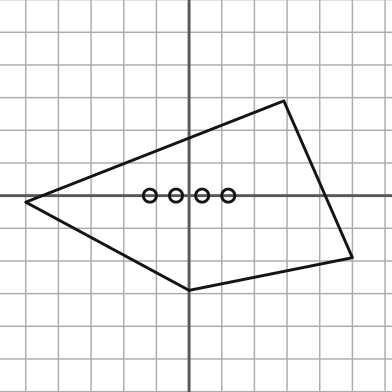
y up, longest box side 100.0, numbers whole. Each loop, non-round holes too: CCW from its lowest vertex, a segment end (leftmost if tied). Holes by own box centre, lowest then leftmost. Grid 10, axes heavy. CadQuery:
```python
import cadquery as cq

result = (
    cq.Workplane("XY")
    .moveTo(0.0, -29.0)
    .lineTo(50.0, -19.0)
    .lineTo(29.0, 29.0)
    .lineTo(-50.0, -2.0)
    .close()
    .moveTo(-12.0, 0.0)
    .circle(2.0)
    .moveTo(-4.0, 0.0)
    .circle(2.0)
    .moveTo(4.0, 0.0)
    .circle(2.0)
    .moveTo(12.0, 0.0)
    .circle(2.0)
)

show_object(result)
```